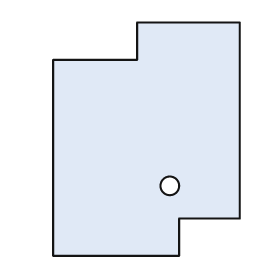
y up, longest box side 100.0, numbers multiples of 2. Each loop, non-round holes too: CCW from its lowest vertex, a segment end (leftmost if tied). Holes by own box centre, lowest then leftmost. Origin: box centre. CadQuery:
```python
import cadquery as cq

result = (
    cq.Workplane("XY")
    .moveTo(-40.0, -50.0)
    .lineTo(14.0, -50.0)
    .lineTo(14.0, -34.0)
    .lineTo(40.0, -34.0)
    .lineTo(40.0, 50.0)
    .lineTo(-4.0, 50.0)
    .lineTo(-4.0, 34.0)
    .lineTo(-40.0, 34.0)
    .close()
    .moveTo(10.0, -20.0)
    .circle(4.0)
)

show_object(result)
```